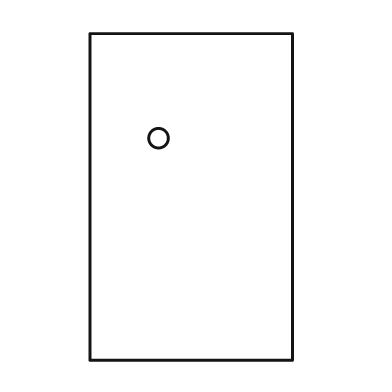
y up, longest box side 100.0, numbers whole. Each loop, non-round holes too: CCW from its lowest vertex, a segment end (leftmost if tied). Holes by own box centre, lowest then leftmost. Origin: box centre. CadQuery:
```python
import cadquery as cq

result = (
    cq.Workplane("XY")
    .moveTo(-31.0, -50.0)
    .lineTo(31.0, -50.0)
    .lineTo(31.0, 50.0)
    .lineTo(-31.0, 50.0)
    .close()
    .moveTo(-10.0, 18.0)
    .circle(3.0)
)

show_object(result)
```